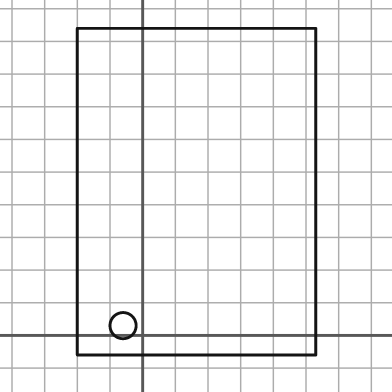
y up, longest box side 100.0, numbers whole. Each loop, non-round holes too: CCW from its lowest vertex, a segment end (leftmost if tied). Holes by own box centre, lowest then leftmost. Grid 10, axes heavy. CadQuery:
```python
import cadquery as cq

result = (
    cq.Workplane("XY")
    .moveTo(-20.0, -6.0)
    .lineTo(53.0, -6.0)
    .lineTo(53.0, 94.0)
    .lineTo(-20.0, 94.0)
    .close()
    .moveTo(-6.0, 3.0)
    .circle(4.0)
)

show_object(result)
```